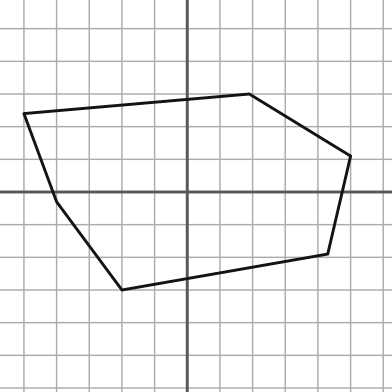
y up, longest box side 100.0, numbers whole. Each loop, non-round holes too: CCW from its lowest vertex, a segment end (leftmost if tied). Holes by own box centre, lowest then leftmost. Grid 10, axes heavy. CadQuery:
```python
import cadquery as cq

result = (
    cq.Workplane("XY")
    .moveTo(-20.0, -30.0)
    .lineTo(43.0, -19.0)
    .lineTo(50.0, 11.0)
    .lineTo(19.0, 30.0)
    .lineTo(-50.0, 24.0)
    .lineTo(-40.0, -3.0)
    .close()
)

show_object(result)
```